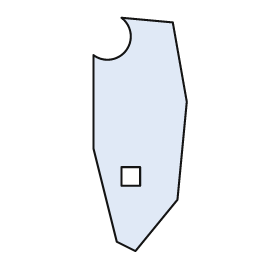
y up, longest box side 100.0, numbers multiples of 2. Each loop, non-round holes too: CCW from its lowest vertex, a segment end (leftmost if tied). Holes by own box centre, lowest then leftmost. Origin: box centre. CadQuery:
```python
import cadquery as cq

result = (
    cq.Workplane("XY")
    .moveTo(-2.0, -50.0)
    .lineTo(16.0, -28.0)
    .lineTo(20.0, 14.0)
    .lineTo(14.0, 48.0)
    .lineTo(-8.0, 50.0)
    .threePointArc((-6.0, 36.0), (-20.0, 34.0))
    .lineTo(-20.0, -6.0)
    .lineTo(-10.0, -46.0)
    .close()
    .moveTo(-8.0, -22.0)
    .lineTo(0.0, -22.0)
    .lineTo(0.0, -14.0)
    .lineTo(-8.0, -14.0)
    .close()
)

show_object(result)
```